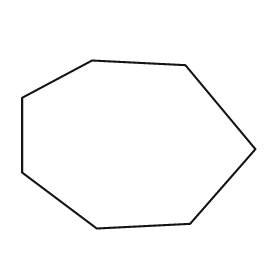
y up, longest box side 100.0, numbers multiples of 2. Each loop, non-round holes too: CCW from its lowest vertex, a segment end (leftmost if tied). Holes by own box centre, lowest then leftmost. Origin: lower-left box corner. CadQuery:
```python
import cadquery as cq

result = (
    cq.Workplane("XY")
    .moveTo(32.0, 0.0)
    .lineTo(72.0, 2.0)
    .lineTo(100.0, 34.0)
    .lineTo(70.0, 70.0)
    .lineTo(30.0, 72.0)
    .lineTo(0.0, 56.0)
    .lineTo(0.0, 24.0)
    .close()
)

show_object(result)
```